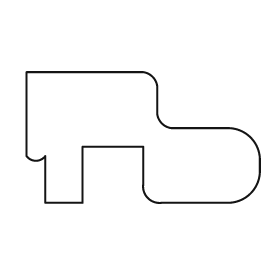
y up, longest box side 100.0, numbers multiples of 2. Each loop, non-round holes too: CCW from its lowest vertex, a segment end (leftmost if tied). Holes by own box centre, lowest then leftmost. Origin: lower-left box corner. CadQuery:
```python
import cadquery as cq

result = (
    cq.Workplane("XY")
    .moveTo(8.0, 0.0)
    .lineTo(24.0, 0.0)
    .lineTo(24.0, 24.0)
    .lineTo(50.0, 24.0)
    .lineTo(50.0, 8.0)
    .threePointArc((52.0, 2.0), (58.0, 0.0))
    .lineTo(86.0, 0.0)
    .threePointArc((96.0, 4.0), (100.0, 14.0))
    .lineTo(100.0, 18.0)
    .threePointArc((96.0, 28.0), (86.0, 32.0))
    .lineTo(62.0, 32.0)
    .threePointArc((58.0, 34.0), (56.0, 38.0))
    .lineTo(56.0, 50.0)
    .threePointArc((54.0, 54.0), (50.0, 56.0))
    .lineTo(0.0, 56.0)
    .lineTo(0.0, 20.0)
    .threePointArc((4.0, 18.0), (8.0, 20.0))
    .close()
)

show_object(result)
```